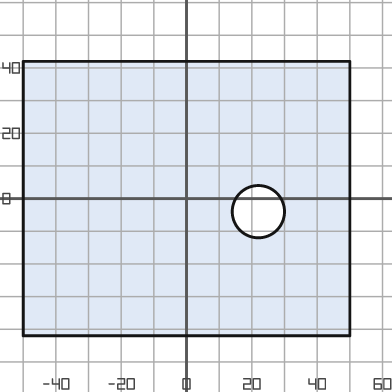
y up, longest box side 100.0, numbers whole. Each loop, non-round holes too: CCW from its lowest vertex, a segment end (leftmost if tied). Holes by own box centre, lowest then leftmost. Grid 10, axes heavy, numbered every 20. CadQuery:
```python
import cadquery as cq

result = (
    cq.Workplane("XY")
    .moveTo(-50.0, -42.0)
    .lineTo(50.0, -42.0)
    .lineTo(50.0, 42.0)
    .lineTo(-50.0, 42.0)
    .close()
    .moveTo(22.0, -4.0)
    .circle(8.0)
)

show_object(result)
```